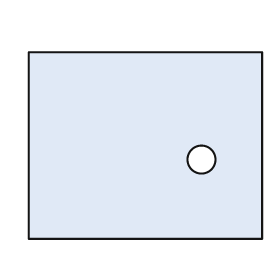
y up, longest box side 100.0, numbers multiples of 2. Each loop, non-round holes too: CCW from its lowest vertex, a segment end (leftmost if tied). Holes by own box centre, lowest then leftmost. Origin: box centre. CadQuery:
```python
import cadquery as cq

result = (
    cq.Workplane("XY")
    .moveTo(-50.0, -40.0)
    .lineTo(50.0, -40.0)
    .lineTo(50.0, 40.0)
    .lineTo(-50.0, 40.0)
    .close()
    .moveTo(24.0, -6.0)
    .circle(6.0)
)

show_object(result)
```